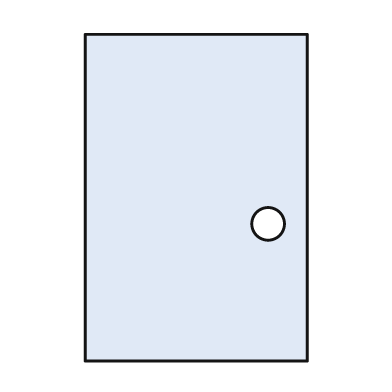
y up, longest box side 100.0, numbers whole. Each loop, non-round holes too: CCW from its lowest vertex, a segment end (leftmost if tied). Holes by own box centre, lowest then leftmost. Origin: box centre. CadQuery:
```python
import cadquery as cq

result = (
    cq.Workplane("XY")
    .moveTo(-34.0, -50.0)
    .lineTo(34.0, -50.0)
    .lineTo(34.0, 50.0)
    .lineTo(-34.0, 50.0)
    .close()
    .moveTo(22.0, -8.0)
    .circle(5.0)
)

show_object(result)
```